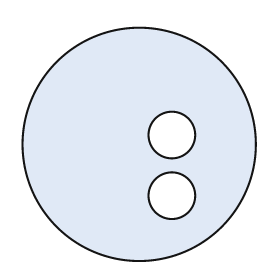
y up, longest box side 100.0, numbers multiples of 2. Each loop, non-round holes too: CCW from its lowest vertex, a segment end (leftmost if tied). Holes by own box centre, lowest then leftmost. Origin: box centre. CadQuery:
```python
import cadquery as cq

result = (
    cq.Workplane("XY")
    .moveTo(0.0, 0.0)
    .circle(50.0)
    .moveTo(14.0, -22.0)
    .circle(10.0)
    .moveTo(14.0, 4.0)
    .circle(10.0)
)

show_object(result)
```